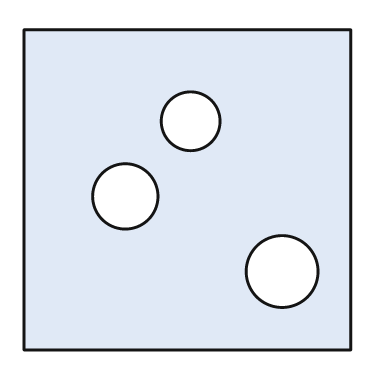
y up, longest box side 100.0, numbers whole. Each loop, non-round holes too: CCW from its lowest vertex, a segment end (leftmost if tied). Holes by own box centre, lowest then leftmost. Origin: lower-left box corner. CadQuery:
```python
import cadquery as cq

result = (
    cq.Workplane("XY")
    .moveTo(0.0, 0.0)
    .lineTo(100.0, 0.0)
    .lineTo(100.0, 98.0)
    .lineTo(0.0, 98.0)
    .close()
    .moveTo(79.0, 24.0)
    .circle(11.0)
    .moveTo(31.0, 47.0)
    .circle(10.0)
    .moveTo(51.0, 70.0)
    .circle(9.0)
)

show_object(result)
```